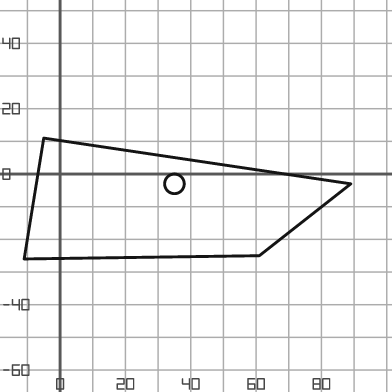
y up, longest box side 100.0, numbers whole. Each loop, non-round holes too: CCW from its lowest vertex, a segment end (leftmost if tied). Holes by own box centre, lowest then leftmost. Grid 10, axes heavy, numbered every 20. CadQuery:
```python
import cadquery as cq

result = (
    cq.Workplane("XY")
    .moveTo(-11.0, -26.0)
    .lineTo(61.0, -25.0)
    .lineTo(89.0, -3.0)
    .lineTo(-5.0, 11.0)
    .close()
    .moveTo(35.0, -3.0)
    .circle(3.0)
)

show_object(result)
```